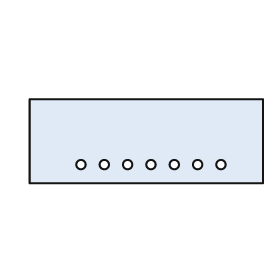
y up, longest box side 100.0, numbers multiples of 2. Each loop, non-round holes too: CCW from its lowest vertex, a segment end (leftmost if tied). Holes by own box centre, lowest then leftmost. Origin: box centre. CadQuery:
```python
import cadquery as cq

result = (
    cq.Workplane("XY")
    .moveTo(-50.0, -18.0)
    .lineTo(50.0, -18.0)
    .lineTo(50.0, 18.0)
    .lineTo(-50.0, 18.0)
    .close()
    .moveTo(-28.0, -10.0)
    .circle(2.0)
    .moveTo(-18.0, -10.0)
    .circle(2.0)
    .moveTo(-8.0, -10.0)
    .circle(2.0)
    .moveTo(2.0, -10.0)
    .circle(2.0)
    .moveTo(12.0, -10.0)
    .circle(2.0)
    .moveTo(22.0, -10.0)
    .circle(2.0)
    .moveTo(32.0, -10.0)
    .circle(2.0)
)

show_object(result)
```